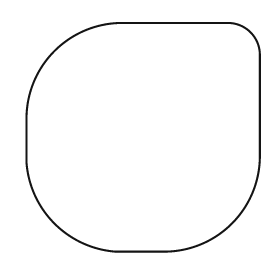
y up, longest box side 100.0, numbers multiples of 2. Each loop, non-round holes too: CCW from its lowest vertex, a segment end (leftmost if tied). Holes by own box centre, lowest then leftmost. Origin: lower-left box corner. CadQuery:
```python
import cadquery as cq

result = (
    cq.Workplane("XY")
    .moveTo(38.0, 0.0)
    .lineTo(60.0, 0.0)
    .threePointArc((88.0, 12.0), (100.0, 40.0))
    .lineTo(100.0, 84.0)
    .threePointArc((96.0, 94.0), (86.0, 98.0))
    .lineTo(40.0, 98.0)
    .threePointArc((12.0, 86.0), (0.0, 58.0))
    .lineTo(0.0, 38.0)
    .threePointArc((12.0, 12.0), (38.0, 0.0))
    .close()
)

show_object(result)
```